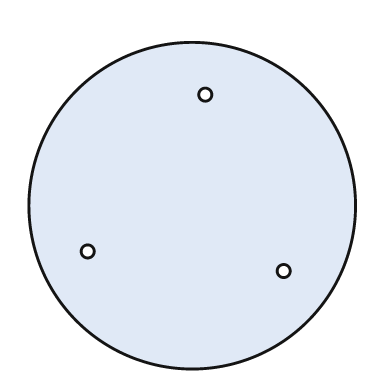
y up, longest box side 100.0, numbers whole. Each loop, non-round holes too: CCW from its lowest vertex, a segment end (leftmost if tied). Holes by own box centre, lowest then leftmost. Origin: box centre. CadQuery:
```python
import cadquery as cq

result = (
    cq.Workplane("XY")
    .moveTo(0.0, 0.0)
    .circle(50.0)
    .moveTo(28.0, -20.0)
    .circle(2.0)
    .moveTo(-32.0, -14.0)
    .circle(2.0)
    .moveTo(4.0, 34.0)
    .circle(2.0)
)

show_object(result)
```